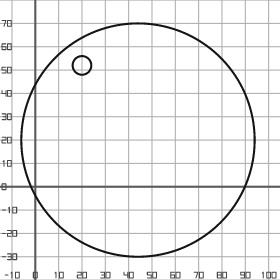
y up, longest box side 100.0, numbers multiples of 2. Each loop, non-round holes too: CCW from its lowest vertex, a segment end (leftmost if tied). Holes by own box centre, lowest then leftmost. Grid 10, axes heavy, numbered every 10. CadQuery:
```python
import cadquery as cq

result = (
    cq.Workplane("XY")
    .moveTo(44.0, 20.0)
    .circle(50.0)
    .moveTo(20.0, 52.0)
    .circle(4.0)
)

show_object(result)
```